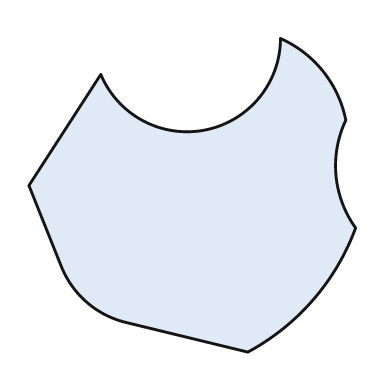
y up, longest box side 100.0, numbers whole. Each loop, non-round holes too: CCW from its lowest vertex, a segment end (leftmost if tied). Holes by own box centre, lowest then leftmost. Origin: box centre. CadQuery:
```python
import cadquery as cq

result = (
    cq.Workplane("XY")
    .moveTo(17.0, -48.0)
    .threePointArc((37.0, -32.0), (50.0, -10.0))
    .threePointArc((44.0, 6.0), (47.0, 23.0))
    .threePointArc((40.0, 38.0), (27.0, 48.0))
    .threePointArc((4.0, 20.0), (-28.0, 37.0))
    .lineTo(-50.0, 3.0)
    .lineTo(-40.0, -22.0)
    .threePointArc((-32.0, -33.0), (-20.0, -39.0))
    .close()
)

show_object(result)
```